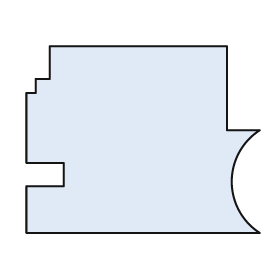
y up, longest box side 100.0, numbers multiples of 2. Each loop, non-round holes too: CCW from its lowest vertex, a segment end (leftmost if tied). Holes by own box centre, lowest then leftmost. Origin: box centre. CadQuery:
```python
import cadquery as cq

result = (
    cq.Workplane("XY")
    .moveTo(-50.0, -40.0)
    .lineTo(50.0, -40.0)
    .threePointArc((38.0, -18.0), (50.0, 4.0))
    .lineTo(36.0, 4.0)
    .lineTo(36.0, 40.0)
    .lineTo(-40.0, 40.0)
    .lineTo(-40.0, 26.0)
    .lineTo(-46.0, 26.0)
    .lineTo(-46.0, 20.0)
    .lineTo(-50.0, 20.0)
    .lineTo(-50.0, -10.0)
    .lineTo(-34.0, -10.0)
    .lineTo(-34.0, -20.0)
    .lineTo(-50.0, -20.0)
    .close()
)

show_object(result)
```